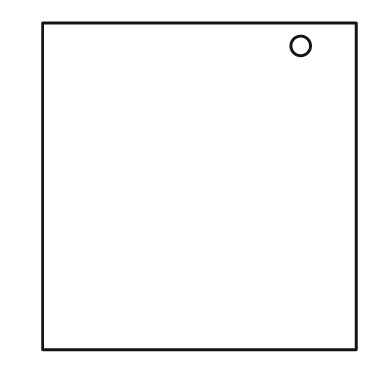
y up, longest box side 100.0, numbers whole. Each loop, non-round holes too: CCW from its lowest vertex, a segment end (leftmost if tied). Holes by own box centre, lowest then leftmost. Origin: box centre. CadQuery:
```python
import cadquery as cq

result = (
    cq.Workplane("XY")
    .moveTo(-48.0, -50.0)
    .lineTo(48.0, -50.0)
    .lineTo(48.0, 50.0)
    .lineTo(-48.0, 50.0)
    .close()
    .moveTo(31.0, 43.0)
    .circle(3.0)
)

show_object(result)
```